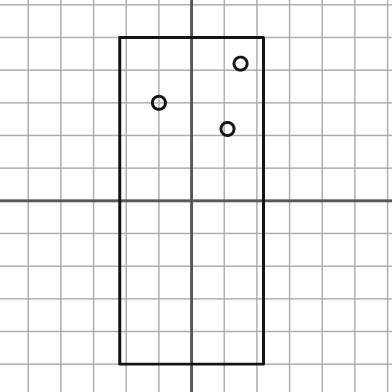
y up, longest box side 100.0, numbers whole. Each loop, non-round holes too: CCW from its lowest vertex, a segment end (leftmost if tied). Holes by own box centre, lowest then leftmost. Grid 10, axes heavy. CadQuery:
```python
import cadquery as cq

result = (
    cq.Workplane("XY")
    .moveTo(-22.0, -50.0)
    .lineTo(22.0, -50.0)
    .lineTo(22.0, 50.0)
    .lineTo(-22.0, 50.0)
    .close()
    .moveTo(11.0, 22.0)
    .circle(2.0)
    .moveTo(-10.0, 30.0)
    .circle(2.0)
    .moveTo(15.0, 42.0)
    .circle(2.0)
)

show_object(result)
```